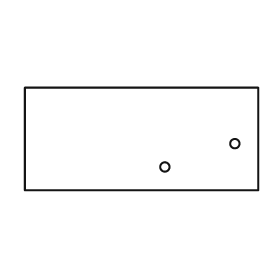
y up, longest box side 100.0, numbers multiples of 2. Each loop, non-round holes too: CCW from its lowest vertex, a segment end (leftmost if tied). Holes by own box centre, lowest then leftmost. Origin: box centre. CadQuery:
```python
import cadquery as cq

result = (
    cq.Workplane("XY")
    .moveTo(-50.0, -22.0)
    .lineTo(50.0, -22.0)
    .lineTo(50.0, 22.0)
    .lineTo(-50.0, 22.0)
    .close()
    .moveTo(10.0, -12.0)
    .circle(2.0)
    .moveTo(40.0, -2.0)
    .circle(2.0)
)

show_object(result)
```